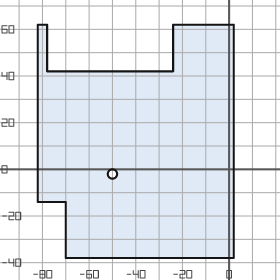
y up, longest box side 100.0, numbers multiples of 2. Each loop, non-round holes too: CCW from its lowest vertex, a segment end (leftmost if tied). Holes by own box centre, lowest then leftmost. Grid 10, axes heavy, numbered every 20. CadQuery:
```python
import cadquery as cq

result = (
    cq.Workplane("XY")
    .moveTo(-70.0, -38.0)
    .lineTo(2.0, -38.0)
    .lineTo(2.0, 62.0)
    .lineTo(-24.0, 62.0)
    .lineTo(-24.0, 42.0)
    .lineTo(-78.0, 42.0)
    .lineTo(-78.0, 62.0)
    .lineTo(-82.0, 62.0)
    .lineTo(-82.0, -14.0)
    .lineTo(-70.0, -14.0)
    .close()
    .moveTo(-50.0, -2.0)
    .circle(2.0)
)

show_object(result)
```